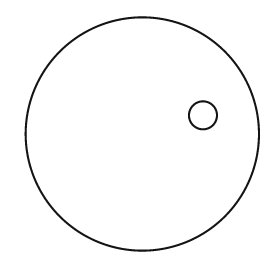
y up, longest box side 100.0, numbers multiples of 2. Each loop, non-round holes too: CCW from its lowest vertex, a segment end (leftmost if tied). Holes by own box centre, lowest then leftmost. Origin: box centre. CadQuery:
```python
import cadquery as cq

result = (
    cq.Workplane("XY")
    .moveTo(0.0, 0.0)
    .circle(50.0)
    .moveTo(26.0, 8.0)
    .circle(6.0)
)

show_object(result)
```